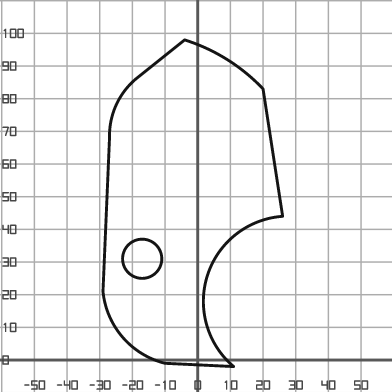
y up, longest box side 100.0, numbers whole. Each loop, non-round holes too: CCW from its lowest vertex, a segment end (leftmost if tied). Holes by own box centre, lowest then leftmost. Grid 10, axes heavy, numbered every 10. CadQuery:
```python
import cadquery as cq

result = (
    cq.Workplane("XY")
    .moveTo(11.0, -2.0)
    .threePointArc((3.0, 26.0), (26.0, 44.0))
    .lineTo(20.0, 83.0)
    .threePointArc((9.0, 92.0), (-4.0, 98.0))
    .lineTo(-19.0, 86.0)
    .threePointArc((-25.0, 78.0), (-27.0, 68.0))
    .lineTo(-29.0, 21.0)
    .threePointArc((-23.0, 7.0), (-10.0, -1.0))
    .close()
    .moveTo(-17.0, 31.0)
    .circle(6.0)
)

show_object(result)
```